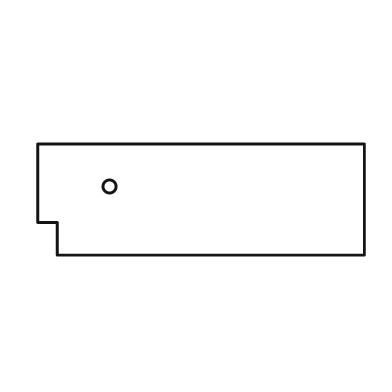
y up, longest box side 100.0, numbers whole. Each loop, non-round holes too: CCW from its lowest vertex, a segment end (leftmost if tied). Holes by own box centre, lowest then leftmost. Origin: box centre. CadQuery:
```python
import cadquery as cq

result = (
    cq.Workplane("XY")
    .moveTo(-44.0, -17.0)
    .lineTo(50.0, -17.0)
    .lineTo(50.0, 17.0)
    .lineTo(-50.0, 17.0)
    .lineTo(-50.0, -7.0)
    .lineTo(-44.0, -7.0)
    .close()
    .moveTo(-28.0, 4.0)
    .circle(2.0)
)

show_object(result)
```